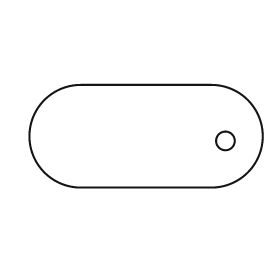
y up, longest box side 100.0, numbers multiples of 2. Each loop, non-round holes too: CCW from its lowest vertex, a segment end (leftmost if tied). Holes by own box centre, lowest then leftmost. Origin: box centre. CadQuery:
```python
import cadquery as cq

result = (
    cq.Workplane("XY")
    .moveTo(-28.0, -22.0)
    .lineTo(28.0, -22.0)
    .threePointArc((50.0, 0.0), (28.0, 22.0))
    .lineTo(-28.0, 22.0)
    .threePointArc((-50.0, 0.0), (-28.0, -22.0))
    .close()
    .moveTo(34.0, -2.0)
    .circle(4.0)
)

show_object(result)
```